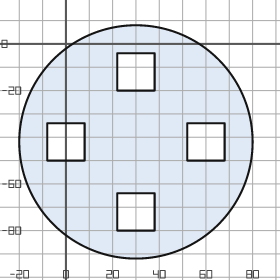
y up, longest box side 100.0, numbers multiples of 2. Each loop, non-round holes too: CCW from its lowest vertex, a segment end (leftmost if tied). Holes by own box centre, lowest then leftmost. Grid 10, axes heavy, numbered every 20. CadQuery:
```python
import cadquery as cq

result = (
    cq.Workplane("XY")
    .moveTo(30.0, -42.0)
    .circle(50.0)
    .moveTo(22.0, -80.0)
    .lineTo(38.0, -80.0)
    .lineTo(38.0, -64.0)
    .lineTo(22.0, -64.0)
    .close()
    .moveTo(-8.0, -50.0)
    .lineTo(8.0, -50.0)
    .lineTo(8.0, -34.0)
    .lineTo(-8.0, -34.0)
    .close()
    .moveTo(52.0, -50.0)
    .lineTo(68.0, -50.0)
    .lineTo(68.0, -34.0)
    .lineTo(52.0, -34.0)
    .close()
    .moveTo(22.0, -20.0)
    .lineTo(38.0, -20.0)
    .lineTo(38.0, -4.0)
    .lineTo(22.0, -4.0)
    .close()
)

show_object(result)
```